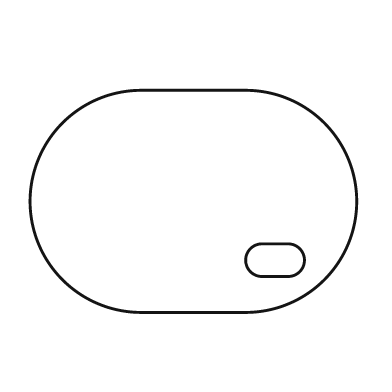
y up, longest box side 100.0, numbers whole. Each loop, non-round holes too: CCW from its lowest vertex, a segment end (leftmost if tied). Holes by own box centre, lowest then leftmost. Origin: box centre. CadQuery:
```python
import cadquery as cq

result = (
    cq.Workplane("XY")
    .moveTo(-16.0, -34.0)
    .lineTo(16.0, -34.0)
    .threePointArc((50.0, 0.0), (16.0, 34.0))
    .lineTo(-16.0, 34.0)
    .threePointArc((-50.0, 0.0), (-16.0, -34.0))
    .close()
    .moveTo(21.0, -23.0)
    .lineTo(29.0, -23.0)
    .threePointArc((34.0, -18.0), (29.0, -13.0))
    .lineTo(21.0, -13.0)
    .threePointArc((16.0, -18.0), (21.0, -23.0))
    .close()
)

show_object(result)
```